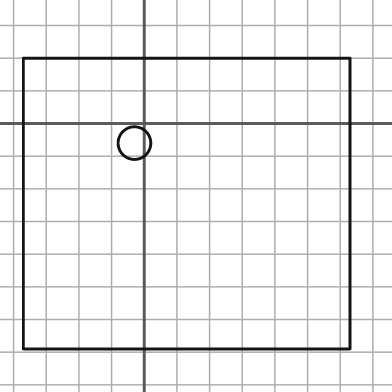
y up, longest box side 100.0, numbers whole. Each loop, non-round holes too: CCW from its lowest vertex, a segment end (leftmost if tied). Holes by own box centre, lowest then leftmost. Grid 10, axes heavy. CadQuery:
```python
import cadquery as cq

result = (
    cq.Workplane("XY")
    .moveTo(-37.0, -69.0)
    .lineTo(63.0, -69.0)
    .lineTo(63.0, 20.0)
    .lineTo(-37.0, 20.0)
    .close()
    .moveTo(-3.0, -6.0)
    .circle(5.0)
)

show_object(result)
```